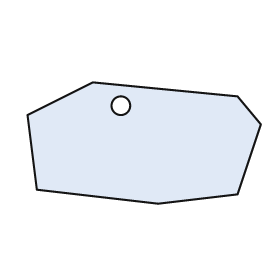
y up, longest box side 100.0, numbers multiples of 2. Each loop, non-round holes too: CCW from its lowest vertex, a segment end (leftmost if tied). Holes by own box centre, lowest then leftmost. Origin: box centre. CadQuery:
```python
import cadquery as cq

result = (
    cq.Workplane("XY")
    .moveTo(6.0, -26.0)
    .lineTo(40.0, -22.0)
    .lineTo(50.0, 8.0)
    .lineTo(40.0, 20.0)
    .lineTo(-22.0, 26.0)
    .lineTo(-50.0, 12.0)
    .lineTo(-46.0, -20.0)
    .close()
    .moveTo(-10.0, 16.0)
    .circle(4.0)
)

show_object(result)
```